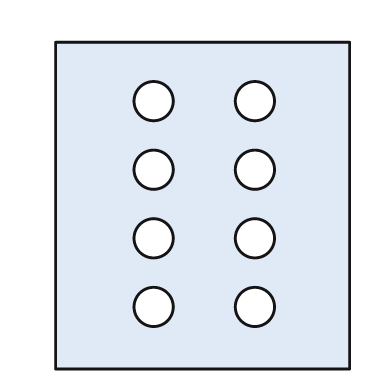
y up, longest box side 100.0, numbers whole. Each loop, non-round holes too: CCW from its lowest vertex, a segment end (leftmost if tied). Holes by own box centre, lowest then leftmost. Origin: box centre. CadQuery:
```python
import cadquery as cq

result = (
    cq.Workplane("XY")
    .moveTo(-45.0, -50.0)
    .lineTo(45.0, -50.0)
    .lineTo(45.0, 50.0)
    .lineTo(-45.0, 50.0)
    .close()
    .moveTo(-15.0, -31.0)
    .circle(6.0)
    .moveTo(16.0, -31.0)
    .circle(6.0)
    .moveTo(-15.0, -10.0)
    .circle(6.0)
    .moveTo(16.0, -10.0)
    .circle(6.0)
    .moveTo(-15.0, 11.0)
    .circle(6.0)
    .moveTo(16.0, 11.0)
    .circle(6.0)
    .moveTo(-15.0, 32.0)
    .circle(6.0)
    .moveTo(16.0, 32.0)
    .circle(6.0)
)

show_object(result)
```